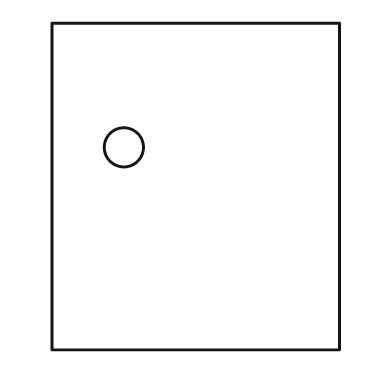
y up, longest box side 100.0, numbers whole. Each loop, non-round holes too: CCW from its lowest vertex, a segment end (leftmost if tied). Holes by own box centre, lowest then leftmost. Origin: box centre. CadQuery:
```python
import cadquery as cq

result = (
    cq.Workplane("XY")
    .moveTo(-44.0, -50.0)
    .lineTo(44.0, -50.0)
    .lineTo(44.0, 50.0)
    .lineTo(-44.0, 50.0)
    .close()
    .moveTo(-22.0, 12.0)
    .circle(6.0)
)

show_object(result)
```